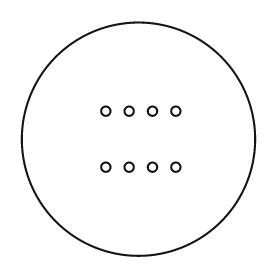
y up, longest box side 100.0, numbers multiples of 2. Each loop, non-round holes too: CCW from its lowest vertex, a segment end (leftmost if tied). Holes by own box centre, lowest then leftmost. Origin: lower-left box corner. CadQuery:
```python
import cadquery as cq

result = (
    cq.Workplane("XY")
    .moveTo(50.0, 50.0)
    .circle(50.0)
    .moveTo(36.0, 38.0)
    .circle(2.0)
    .moveTo(46.0, 38.0)
    .circle(2.0)
    .moveTo(56.0, 38.0)
    .circle(2.0)
    .moveTo(66.0, 38.0)
    .circle(2.0)
    .moveTo(36.0, 62.0)
    .circle(2.0)
    .moveTo(46.0, 62.0)
    .circle(2.0)
    .moveTo(56.0, 62.0)
    .circle(2.0)
    .moveTo(66.0, 62.0)
    .circle(2.0)
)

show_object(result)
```